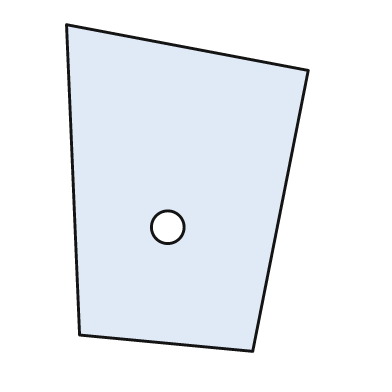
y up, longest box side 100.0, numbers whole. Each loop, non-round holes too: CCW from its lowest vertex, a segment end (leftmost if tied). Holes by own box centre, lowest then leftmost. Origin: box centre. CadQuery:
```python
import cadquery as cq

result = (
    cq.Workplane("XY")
    .moveTo(20.0, -50.0)
    .lineTo(37.0, 36.0)
    .lineTo(-37.0, 50.0)
    .lineTo(-33.0, -45.0)
    .close()
    .moveTo(-6.0, -12.0)
    .circle(5.0)
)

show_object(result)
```